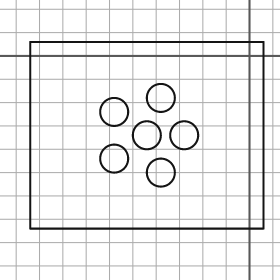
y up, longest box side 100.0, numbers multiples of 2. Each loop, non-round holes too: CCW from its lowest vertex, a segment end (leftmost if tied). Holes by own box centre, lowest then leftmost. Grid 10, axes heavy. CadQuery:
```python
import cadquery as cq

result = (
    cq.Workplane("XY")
    .moveTo(-94.0, -74.0)
    .lineTo(6.0, -74.0)
    .lineTo(6.0, 6.0)
    .lineTo(-94.0, 6.0)
    .close()
    .moveTo(-38.0, -50.0)
    .circle(6.0)
    .moveTo(-58.0, -44.0)
    .circle(6.0)
    .moveTo(-44.0, -34.0)
    .circle(6.0)
    .moveTo(-28.0, -34.0)
    .circle(6.0)
    .moveTo(-58.0, -24.0)
    .circle(6.0)
    .moveTo(-38.0, -18.0)
    .circle(6.0)
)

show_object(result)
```